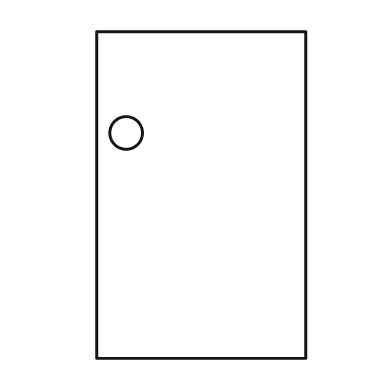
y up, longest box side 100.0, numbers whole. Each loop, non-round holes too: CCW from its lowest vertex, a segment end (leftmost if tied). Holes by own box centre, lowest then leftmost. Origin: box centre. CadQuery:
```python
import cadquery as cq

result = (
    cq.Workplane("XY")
    .moveTo(-32.0, -50.0)
    .lineTo(32.0, -50.0)
    .lineTo(32.0, 50.0)
    .lineTo(-32.0, 50.0)
    .close()
    .moveTo(-23.0, 19.0)
    .circle(5.0)
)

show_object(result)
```